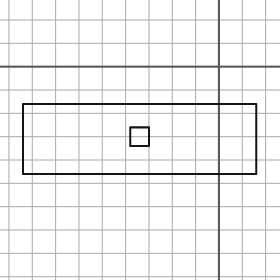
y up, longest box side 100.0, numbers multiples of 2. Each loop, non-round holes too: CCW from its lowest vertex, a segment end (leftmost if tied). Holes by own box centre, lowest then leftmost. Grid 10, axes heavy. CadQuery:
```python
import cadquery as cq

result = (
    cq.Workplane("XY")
    .moveTo(-84.0, -46.0)
    .lineTo(16.0, -46.0)
    .lineTo(16.0, -16.0)
    .lineTo(-84.0, -16.0)
    .close()
    .moveTo(-38.0, -34.0)
    .lineTo(-30.0, -34.0)
    .lineTo(-30.0, -26.0)
    .lineTo(-38.0, -26.0)
    .close()
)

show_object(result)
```